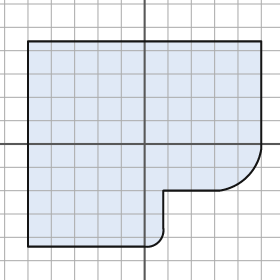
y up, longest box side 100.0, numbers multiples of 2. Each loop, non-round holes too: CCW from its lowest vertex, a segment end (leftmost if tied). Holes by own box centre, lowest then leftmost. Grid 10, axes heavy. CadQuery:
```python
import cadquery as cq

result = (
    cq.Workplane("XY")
    .moveTo(-50.0, -44.0)
    .lineTo(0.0, -44.0)
    .threePointArc((6.0, -42.0), (8.0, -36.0))
    .lineTo(8.0, -20.0)
    .lineTo(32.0, -20.0)
    .threePointArc((44.0, -14.0), (50.0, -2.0))
    .lineTo(50.0, 44.0)
    .lineTo(-50.0, 44.0)
    .close()
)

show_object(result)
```